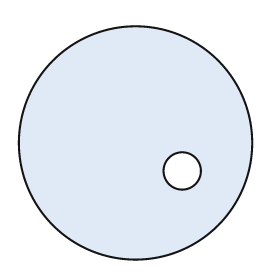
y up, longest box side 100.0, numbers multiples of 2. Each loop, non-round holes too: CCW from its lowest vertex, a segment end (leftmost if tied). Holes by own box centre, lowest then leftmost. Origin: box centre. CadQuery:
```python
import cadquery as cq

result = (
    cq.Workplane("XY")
    .moveTo(0.0, 0.0)
    .circle(50.0)
    .moveTo(20.0, -12.0)
    .circle(8.0)
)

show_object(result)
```